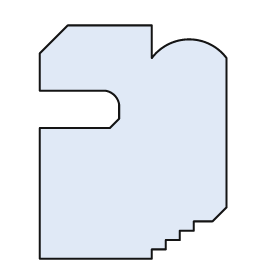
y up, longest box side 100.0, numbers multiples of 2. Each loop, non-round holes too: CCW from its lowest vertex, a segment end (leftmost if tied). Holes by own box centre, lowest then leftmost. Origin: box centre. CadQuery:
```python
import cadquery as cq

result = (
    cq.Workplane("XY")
    .moveTo(-40.0, -50.0)
    .lineTo(8.0, -50.0)
    .lineTo(8.0, -46.0)
    .lineTo(14.0, -46.0)
    .lineTo(14.0, -42.0)
    .lineTo(20.0, -42.0)
    .lineTo(20.0, -38.0)
    .lineTo(26.0, -38.0)
    .lineTo(26.0, -34.0)
    .lineTo(34.0, -34.0)
    .lineTo(40.0, -28.0)
    .lineTo(40.0, 36.0)
    .threePointArc((24.0, 44.0), (8.0, 36.0))
    .lineTo(8.0, 50.0)
    .lineTo(-28.0, 50.0)
    .lineTo(-40.0, 38.0)
    .lineTo(-40.0, 22.0)
    .lineTo(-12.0, 22.0)
    .threePointArc((-8.0, 20.0), (-6.0, 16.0))
    .lineTo(-6.0, 10.0)
    .lineTo(-10.0, 6.0)
    .lineTo(-40.0, 6.0)
    .close()
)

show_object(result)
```